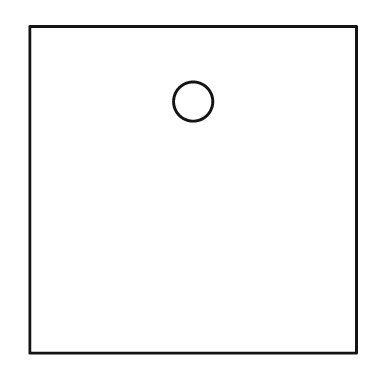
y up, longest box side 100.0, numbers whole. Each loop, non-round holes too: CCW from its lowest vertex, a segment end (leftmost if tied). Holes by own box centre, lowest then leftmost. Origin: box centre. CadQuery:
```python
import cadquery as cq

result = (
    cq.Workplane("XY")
    .moveTo(-50.0, -50.0)
    .lineTo(50.0, -50.0)
    .lineTo(50.0, 50.0)
    .lineTo(-50.0, 50.0)
    .close()
    .moveTo(0.0, 27.0)
    .circle(6.0)
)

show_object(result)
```